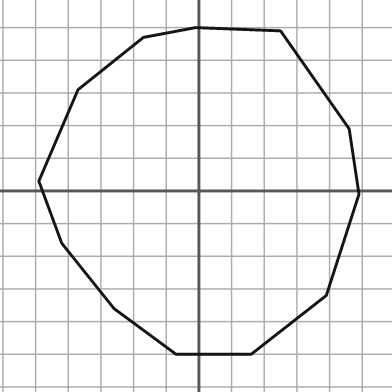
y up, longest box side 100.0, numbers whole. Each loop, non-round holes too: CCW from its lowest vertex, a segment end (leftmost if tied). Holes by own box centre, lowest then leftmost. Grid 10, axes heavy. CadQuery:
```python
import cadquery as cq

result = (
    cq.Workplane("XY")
    .moveTo(-7.0, -50.0)
    .lineTo(16.0, -50.0)
    .lineTo(39.0, -32.0)
    .lineTo(49.0, -1.0)
    .lineTo(46.0, 19.0)
    .lineTo(25.0, 49.0)
    .lineTo(-1.0, 50.0)
    .lineTo(-17.0, 47.0)
    .lineTo(-37.0, 31.0)
    .lineTo(-49.0, 3.0)
    .lineTo(-42.0, -16.0)
    .lineTo(-26.0, -36.0)
    .close()
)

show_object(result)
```